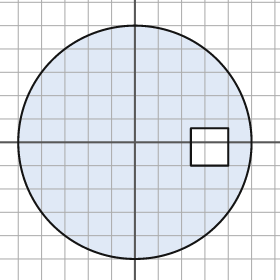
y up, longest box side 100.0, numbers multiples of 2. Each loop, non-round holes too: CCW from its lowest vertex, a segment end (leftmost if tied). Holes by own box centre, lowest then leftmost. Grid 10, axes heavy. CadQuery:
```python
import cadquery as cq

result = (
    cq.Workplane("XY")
    .moveTo(0.0, 0.0)
    .circle(50.0)
    .moveTo(24.0, -10.0)
    .lineTo(40.0, -10.0)
    .lineTo(40.0, 6.0)
    .lineTo(24.0, 6.0)
    .close()
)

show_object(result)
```